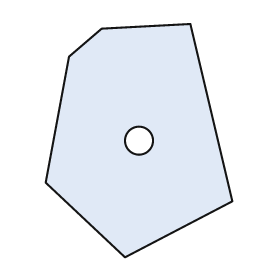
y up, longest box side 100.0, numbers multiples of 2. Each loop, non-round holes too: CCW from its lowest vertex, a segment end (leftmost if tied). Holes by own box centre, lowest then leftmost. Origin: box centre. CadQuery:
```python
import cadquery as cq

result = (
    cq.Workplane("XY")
    .moveTo(-6.0, -50.0)
    .lineTo(40.0, -26.0)
    .lineTo(22.0, 50.0)
    .lineTo(-16.0, 48.0)
    .lineTo(-30.0, 36.0)
    .lineTo(-40.0, -18.0)
    .close()
    .moveTo(0.0, 0.0)
    .circle(6.0)
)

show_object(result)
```